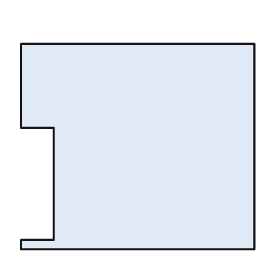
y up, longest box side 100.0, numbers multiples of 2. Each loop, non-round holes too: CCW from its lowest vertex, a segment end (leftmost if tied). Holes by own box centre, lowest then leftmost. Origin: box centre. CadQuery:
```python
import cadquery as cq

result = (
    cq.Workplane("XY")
    .moveTo(-50.0, -44.0)
    .lineTo(50.0, -44.0)
    .lineTo(50.0, 44.0)
    .lineTo(-50.0, 44.0)
    .lineTo(-50.0, 8.0)
    .lineTo(-36.0, 8.0)
    .lineTo(-36.0, -40.0)
    .lineTo(-50.0, -40.0)
    .close()
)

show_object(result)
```